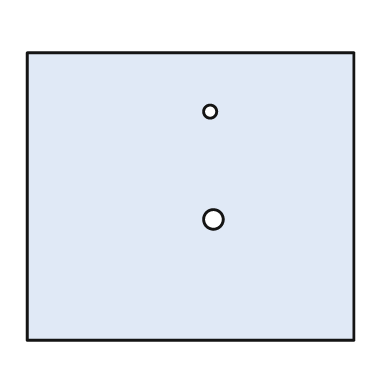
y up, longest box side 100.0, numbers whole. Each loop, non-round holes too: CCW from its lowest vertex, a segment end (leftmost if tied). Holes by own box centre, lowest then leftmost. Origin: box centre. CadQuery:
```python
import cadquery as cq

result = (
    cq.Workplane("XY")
    .moveTo(-50.0, -44.0)
    .lineTo(50.0, -44.0)
    .lineTo(50.0, 44.0)
    .lineTo(-50.0, 44.0)
    .close()
    .moveTo(7.0, -7.0)
    .circle(3.0)
    .moveTo(6.0, 26.0)
    .circle(2.0)
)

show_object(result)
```